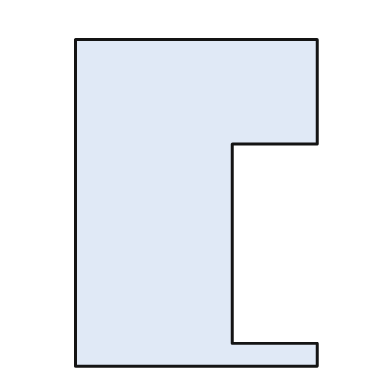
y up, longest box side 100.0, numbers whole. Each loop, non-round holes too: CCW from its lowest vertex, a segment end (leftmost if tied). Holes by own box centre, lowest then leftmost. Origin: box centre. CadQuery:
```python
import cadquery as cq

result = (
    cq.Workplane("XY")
    .moveTo(-37.0, -50.0)
    .lineTo(37.0, -50.0)
    .lineTo(37.0, -43.0)
    .lineTo(11.0, -43.0)
    .lineTo(11.0, 18.0)
    .lineTo(37.0, 18.0)
    .lineTo(37.0, 50.0)
    .lineTo(-37.0, 50.0)
    .close()
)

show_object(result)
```